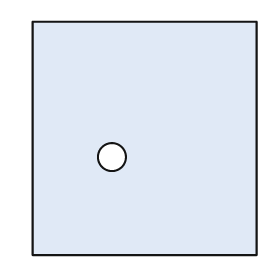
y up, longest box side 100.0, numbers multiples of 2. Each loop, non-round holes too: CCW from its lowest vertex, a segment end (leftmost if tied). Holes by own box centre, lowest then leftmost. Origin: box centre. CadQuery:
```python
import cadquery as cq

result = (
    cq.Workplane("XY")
    .moveTo(-48.0, -50.0)
    .lineTo(48.0, -50.0)
    .lineTo(48.0, 50.0)
    .lineTo(-48.0, 50.0)
    .close()
    .moveTo(-14.0, -8.0)
    .circle(6.0)
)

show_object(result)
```